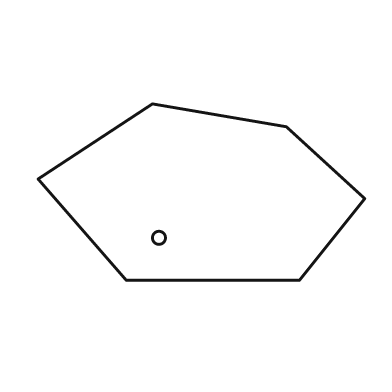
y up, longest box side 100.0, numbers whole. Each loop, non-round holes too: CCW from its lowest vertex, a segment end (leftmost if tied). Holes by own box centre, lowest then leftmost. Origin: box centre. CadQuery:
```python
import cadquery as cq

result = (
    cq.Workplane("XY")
    .moveTo(-23.0, -27.0)
    .lineTo(30.0, -27.0)
    .lineTo(50.0, -2.0)
    .lineTo(26.0, 20.0)
    .lineTo(-15.0, 27.0)
    .lineTo(-50.0, 4.0)
    .close()
    .moveTo(-13.0, -14.0)
    .circle(2.0)
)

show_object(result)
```